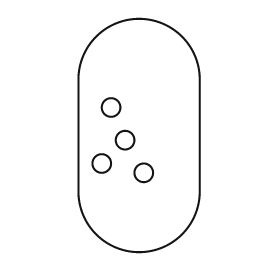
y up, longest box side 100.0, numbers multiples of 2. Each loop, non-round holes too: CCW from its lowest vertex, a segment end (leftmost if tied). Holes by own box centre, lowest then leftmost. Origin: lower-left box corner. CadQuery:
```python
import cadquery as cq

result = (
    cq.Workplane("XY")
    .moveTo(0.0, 26.0)
    .threePointArc((26.0, 0.0), (52.0, 26.0))
    .lineTo(52.0, 74.0)
    .threePointArc((26.0, 100.0), (0.0, 74.0))
    .close()
    .moveTo(28.0, 34.0)
    .circle(4.0)
    .moveTo(10.0, 38.0)
    .circle(4.0)
    .moveTo(20.0, 48.0)
    .circle(4.0)
    .moveTo(14.0, 62.0)
    .circle(4.0)
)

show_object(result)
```